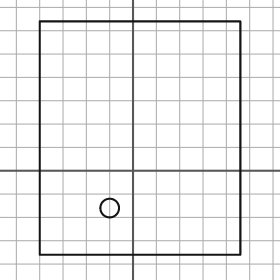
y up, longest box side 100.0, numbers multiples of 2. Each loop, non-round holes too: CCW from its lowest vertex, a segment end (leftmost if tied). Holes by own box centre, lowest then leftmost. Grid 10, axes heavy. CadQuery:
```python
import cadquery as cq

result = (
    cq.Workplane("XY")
    .moveTo(-40.0, -36.0)
    .lineTo(46.0, -36.0)
    .lineTo(46.0, 64.0)
    .lineTo(-40.0, 64.0)
    .close()
    .moveTo(-10.0, -16.0)
    .circle(4.0)
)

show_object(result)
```